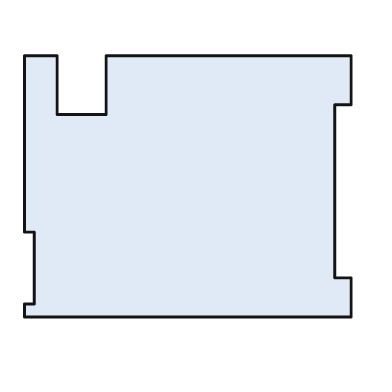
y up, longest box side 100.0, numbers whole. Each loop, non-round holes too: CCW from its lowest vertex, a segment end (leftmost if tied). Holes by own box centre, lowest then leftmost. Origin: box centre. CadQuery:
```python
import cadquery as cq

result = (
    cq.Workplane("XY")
    .moveTo(-50.0, -40.0)
    .lineTo(50.0, -40.0)
    .lineTo(50.0, -28.0)
    .lineTo(45.0, -28.0)
    .lineTo(45.0, 25.0)
    .lineTo(50.0, 25.0)
    .lineTo(50.0, 40.0)
    .lineTo(-25.0, 40.0)
    .lineTo(-25.0, 22.0)
    .lineTo(-40.0, 22.0)
    .lineTo(-40.0, 40.0)
    .lineTo(-50.0, 40.0)
    .lineTo(-50.0, -14.0)
    .lineTo(-47.0, -14.0)
    .lineTo(-47.0, -36.0)
    .lineTo(-50.0, -36.0)
    .close()
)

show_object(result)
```